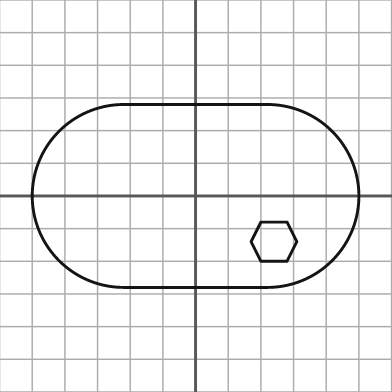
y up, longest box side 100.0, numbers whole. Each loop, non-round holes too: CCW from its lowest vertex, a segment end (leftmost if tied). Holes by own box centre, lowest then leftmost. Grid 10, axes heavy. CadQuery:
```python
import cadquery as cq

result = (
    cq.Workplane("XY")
    .moveTo(-22.0, -28.0)
    .lineTo(22.0, -28.0)
    .threePointArc((50.0, 0.0), (22.0, 28.0))
    .lineTo(-22.0, 28.0)
    .threePointArc((-50.0, 0.0), (-22.0, -28.0))
    .close()
    .moveTo(20.0, -20.0)
    .lineTo(28.0, -20.0)
    .lineTo(31.0, -14.0)
    .lineTo(28.0, -8.0)
    .lineTo(20.0, -8.0)
    .lineTo(17.0, -14.0)
    .close()
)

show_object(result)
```